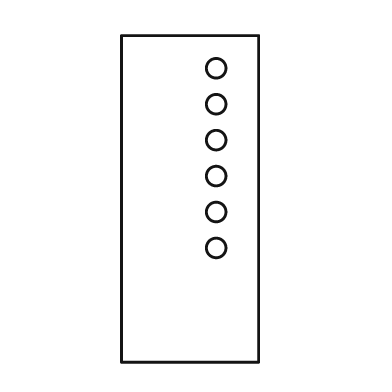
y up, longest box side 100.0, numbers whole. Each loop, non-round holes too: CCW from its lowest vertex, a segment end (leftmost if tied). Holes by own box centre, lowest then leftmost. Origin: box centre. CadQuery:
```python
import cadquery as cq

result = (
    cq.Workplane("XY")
    .moveTo(-21.0, -50.0)
    .lineTo(21.0, -50.0)
    .lineTo(21.0, 50.0)
    .lineTo(-21.0, 50.0)
    .close()
    .moveTo(8.0, -15.0)
    .circle(3.0)
    .moveTo(8.0, -4.0)
    .circle(3.0)
    .moveTo(8.0, 7.0)
    .circle(3.0)
    .moveTo(8.0, 18.0)
    .circle(3.0)
    .moveTo(8.0, 29.0)
    .circle(3.0)
    .moveTo(8.0, 40.0)
    .circle(3.0)
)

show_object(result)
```